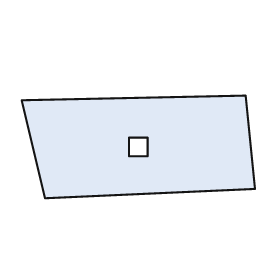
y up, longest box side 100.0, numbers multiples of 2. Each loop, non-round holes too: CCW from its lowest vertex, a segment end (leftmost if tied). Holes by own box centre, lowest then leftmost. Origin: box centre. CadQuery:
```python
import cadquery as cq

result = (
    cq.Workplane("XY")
    .moveTo(-40.0, -22.0)
    .lineTo(50.0, -18.0)
    .lineTo(46.0, 22.0)
    .lineTo(-50.0, 20.0)
    .close()
    .moveTo(-4.0, -4.0)
    .lineTo(4.0, -4.0)
    .lineTo(4.0, 4.0)
    .lineTo(-4.0, 4.0)
    .close()
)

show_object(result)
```